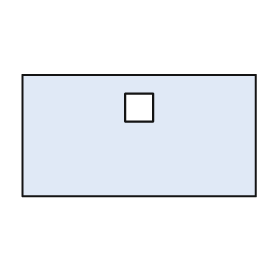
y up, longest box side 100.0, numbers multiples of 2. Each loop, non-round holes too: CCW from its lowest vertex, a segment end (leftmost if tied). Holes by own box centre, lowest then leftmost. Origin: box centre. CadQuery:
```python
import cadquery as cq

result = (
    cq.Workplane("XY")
    .moveTo(-50.0, -26.0)
    .lineTo(50.0, -26.0)
    .lineTo(50.0, 26.0)
    .lineTo(-50.0, 26.0)
    .close()
    .moveTo(-6.0, 6.0)
    .lineTo(6.0, 6.0)
    .lineTo(6.0, 18.0)
    .lineTo(-6.0, 18.0)
    .close()
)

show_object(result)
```